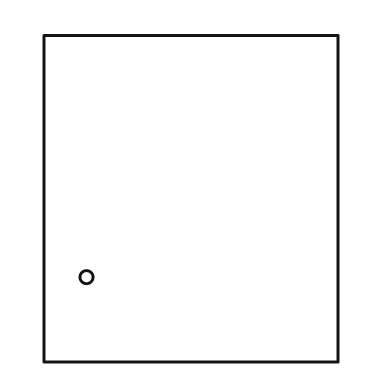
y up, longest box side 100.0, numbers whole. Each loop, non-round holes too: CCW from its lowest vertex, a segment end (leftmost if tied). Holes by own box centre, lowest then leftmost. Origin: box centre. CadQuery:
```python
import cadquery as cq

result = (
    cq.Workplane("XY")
    .moveTo(-45.0, -50.0)
    .lineTo(45.0, -50.0)
    .lineTo(45.0, 50.0)
    .lineTo(-45.0, 50.0)
    .close()
    .moveTo(-32.0, -24.0)
    .circle(2.0)
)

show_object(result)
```